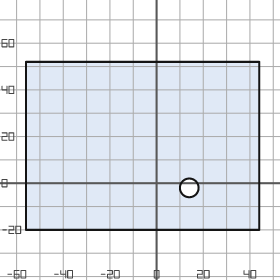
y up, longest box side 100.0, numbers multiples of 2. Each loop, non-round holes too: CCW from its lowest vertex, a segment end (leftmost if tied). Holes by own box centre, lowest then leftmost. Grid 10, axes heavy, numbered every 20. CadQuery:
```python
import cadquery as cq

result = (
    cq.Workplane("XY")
    .moveTo(-56.0, -20.0)
    .lineTo(44.0, -20.0)
    .lineTo(44.0, 52.0)
    .lineTo(-56.0, 52.0)
    .close()
    .moveTo(14.0, -2.0)
    .circle(4.0)
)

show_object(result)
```